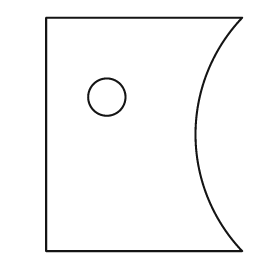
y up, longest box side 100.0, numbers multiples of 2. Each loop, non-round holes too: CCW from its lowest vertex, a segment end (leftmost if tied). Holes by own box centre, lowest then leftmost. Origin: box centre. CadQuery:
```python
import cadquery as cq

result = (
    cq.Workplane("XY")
    .moveTo(-42.0, -50.0)
    .lineTo(42.0, -50.0)
    .threePointArc((22.0, 0.0), (42.0, 50.0))
    .lineTo(-42.0, 50.0)
    .close()
    .moveTo(-16.0, 16.0)
    .circle(8.0)
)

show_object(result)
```